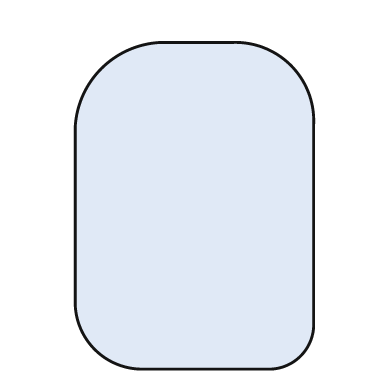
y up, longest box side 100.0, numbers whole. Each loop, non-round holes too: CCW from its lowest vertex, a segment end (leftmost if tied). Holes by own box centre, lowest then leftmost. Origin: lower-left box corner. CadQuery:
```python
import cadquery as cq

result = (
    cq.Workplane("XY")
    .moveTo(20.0, 0.0)
    .lineTo(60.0, 0.0)
    .threePointArc((69.0, 4.0), (73.0, 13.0))
    .lineTo(73.0, 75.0)
    .threePointArc((66.0, 93.0), (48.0, 100.0))
    .lineTo(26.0, 100.0)
    .threePointArc((8.0, 92.0), (0.0, 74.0))
    .lineTo(0.0, 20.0)
    .threePointArc((6.0, 6.0), (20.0, 0.0))
    .close()
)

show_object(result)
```